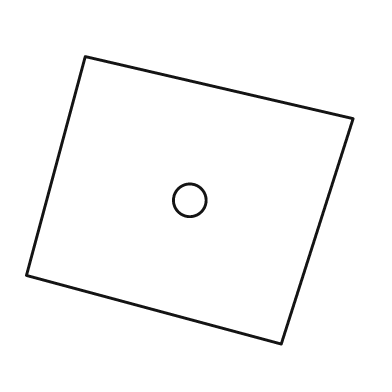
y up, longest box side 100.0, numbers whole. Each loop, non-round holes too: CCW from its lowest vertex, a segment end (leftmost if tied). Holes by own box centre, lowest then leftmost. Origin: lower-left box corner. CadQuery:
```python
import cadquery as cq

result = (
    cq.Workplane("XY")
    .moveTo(78.0, 0.0)
    .lineTo(100.0, 69.0)
    .lineTo(18.0, 88.0)
    .lineTo(0.0, 21.0)
    .close()
    .moveTo(50.0, 44.0)
    .circle(5.0)
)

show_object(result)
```